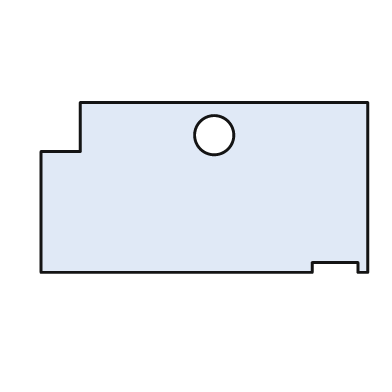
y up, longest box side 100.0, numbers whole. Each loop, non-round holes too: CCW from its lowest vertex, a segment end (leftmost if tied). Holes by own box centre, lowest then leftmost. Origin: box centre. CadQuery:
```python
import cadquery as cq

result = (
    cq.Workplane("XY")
    .moveTo(-50.0, -26.0)
    .lineTo(33.0, -26.0)
    .lineTo(33.0, -23.0)
    .lineTo(47.0, -23.0)
    .lineTo(47.0, -26.0)
    .lineTo(50.0, -26.0)
    .lineTo(50.0, 26.0)
    .lineTo(-38.0, 26.0)
    .lineTo(-38.0, 11.0)
    .lineTo(-50.0, 11.0)
    .close()
    .moveTo(3.0, 16.0)
    .circle(6.0)
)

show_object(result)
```